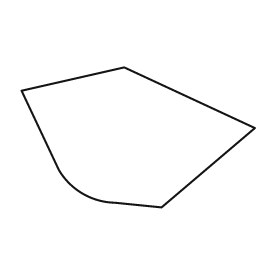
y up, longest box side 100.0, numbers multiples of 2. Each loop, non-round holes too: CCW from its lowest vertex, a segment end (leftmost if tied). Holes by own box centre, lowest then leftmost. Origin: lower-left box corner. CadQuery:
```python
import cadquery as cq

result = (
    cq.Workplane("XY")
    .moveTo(60.0, 0.0)
    .lineTo(100.0, 34.0)
    .lineTo(44.0, 60.0)
    .lineTo(0.0, 50.0)
    .lineTo(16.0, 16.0)
    .threePointArc((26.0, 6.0), (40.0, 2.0))
    .close()
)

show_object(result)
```